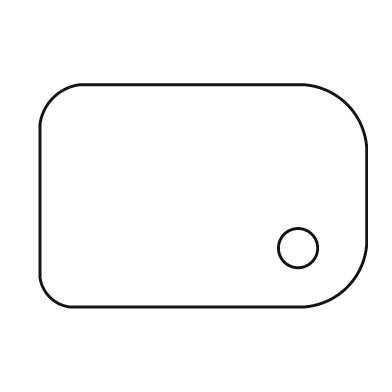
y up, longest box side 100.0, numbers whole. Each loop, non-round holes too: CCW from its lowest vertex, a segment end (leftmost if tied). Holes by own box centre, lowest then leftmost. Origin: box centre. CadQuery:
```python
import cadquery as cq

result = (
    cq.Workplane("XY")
    .moveTo(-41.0, -34.0)
    .lineTo(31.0, -34.0)
    .threePointArc((44.0, -28.0), (50.0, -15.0))
    .lineTo(50.0, 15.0)
    .threePointArc((44.0, 28.0), (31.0, 34.0))
    .lineTo(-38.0, 34.0)
    .threePointArc((-46.0, 30.0), (-50.0, 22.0))
    .lineTo(-50.0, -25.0)
    .threePointArc((-47.0, -31.0), (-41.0, -34.0))
    .close()
    .moveTo(29.0, -16.0)
    .circle(6.0)
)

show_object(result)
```